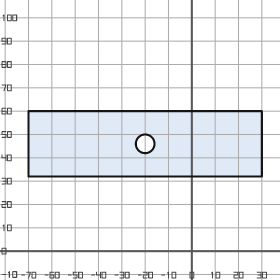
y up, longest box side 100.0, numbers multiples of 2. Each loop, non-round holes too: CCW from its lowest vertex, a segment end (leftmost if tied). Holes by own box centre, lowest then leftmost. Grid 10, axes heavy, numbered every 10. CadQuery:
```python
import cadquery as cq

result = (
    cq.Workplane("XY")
    .moveTo(-70.0, 32.0)
    .lineTo(30.0, 32.0)
    .lineTo(30.0, 60.0)
    .lineTo(-70.0, 60.0)
    .close()
    .moveTo(-20.0, 46.0)
    .circle(4.0)
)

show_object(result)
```